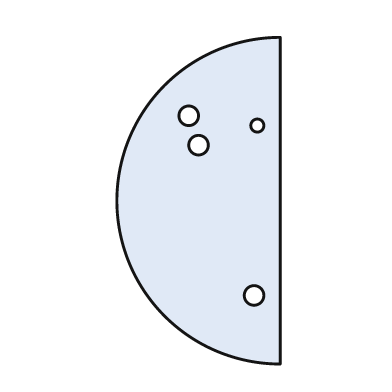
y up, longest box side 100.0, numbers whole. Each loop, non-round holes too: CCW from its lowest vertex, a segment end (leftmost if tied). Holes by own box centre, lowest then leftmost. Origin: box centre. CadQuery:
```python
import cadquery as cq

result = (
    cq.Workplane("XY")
    .moveTo(25.0, -50.0)
    .lineTo(25.0, 50.0)
    .threePointArc((-25.0, 0.0), (25.0, -50.0))
    .close()
    .moveTo(17.0, -29.0)
    .circle(3.0)
    .moveTo(0.0, 17.0)
    .circle(3.0)
    .moveTo(18.0, 23.0)
    .circle(2.0)
    .moveTo(-3.0, 26.0)
    .circle(3.0)
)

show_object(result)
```